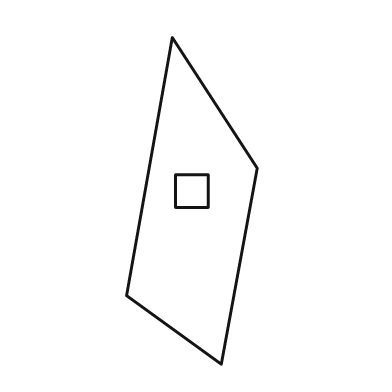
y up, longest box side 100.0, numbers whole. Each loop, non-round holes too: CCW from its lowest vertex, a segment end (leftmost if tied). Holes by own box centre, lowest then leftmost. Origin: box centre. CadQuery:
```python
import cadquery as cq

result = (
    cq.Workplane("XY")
    .moveTo(9.0, -50.0)
    .lineTo(20.0, 10.0)
    .lineTo(-6.0, 50.0)
    .lineTo(-20.0, -29.0)
    .close()
    .moveTo(-5.0, -2.0)
    .lineTo(5.0, -2.0)
    .lineTo(5.0, 8.0)
    .lineTo(-5.0, 8.0)
    .close()
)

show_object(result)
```